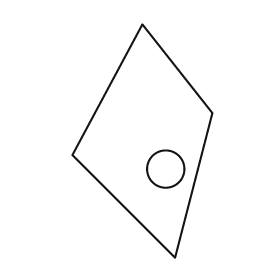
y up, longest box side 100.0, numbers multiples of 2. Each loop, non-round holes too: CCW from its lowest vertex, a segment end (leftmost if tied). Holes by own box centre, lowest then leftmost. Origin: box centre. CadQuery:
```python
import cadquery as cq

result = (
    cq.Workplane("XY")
    .moveTo(14.0, -50.0)
    .lineTo(30.0, 12.0)
    .lineTo(0.0, 50.0)
    .lineTo(-30.0, -6.0)
    .close()
    .moveTo(10.0, -12.0)
    .circle(8.0)
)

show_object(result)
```